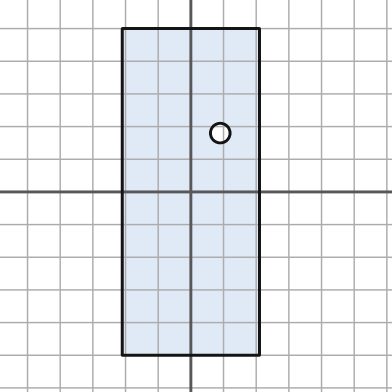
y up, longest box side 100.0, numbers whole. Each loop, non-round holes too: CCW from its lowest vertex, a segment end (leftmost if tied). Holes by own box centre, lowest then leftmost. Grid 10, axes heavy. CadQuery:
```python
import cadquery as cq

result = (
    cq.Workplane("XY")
    .moveTo(-21.0, -50.0)
    .lineTo(21.0, -50.0)
    .lineTo(21.0, 50.0)
    .lineTo(-21.0, 50.0)
    .close()
    .moveTo(9.0, 18.0)
    .circle(3.0)
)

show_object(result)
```